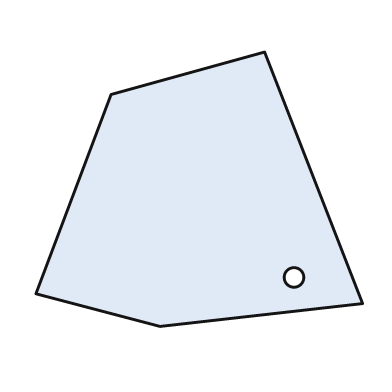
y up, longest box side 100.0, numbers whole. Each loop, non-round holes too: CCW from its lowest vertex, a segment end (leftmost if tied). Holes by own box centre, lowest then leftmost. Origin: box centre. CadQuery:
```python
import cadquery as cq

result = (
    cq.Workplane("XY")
    .moveTo(-12.0, -42.0)
    .lineTo(50.0, -35.0)
    .lineTo(20.0, 42.0)
    .lineTo(-27.0, 29.0)
    .lineTo(-50.0, -32.0)
    .close()
    .moveTo(29.0, -27.0)
    .circle(3.0)
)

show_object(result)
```